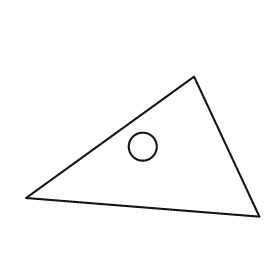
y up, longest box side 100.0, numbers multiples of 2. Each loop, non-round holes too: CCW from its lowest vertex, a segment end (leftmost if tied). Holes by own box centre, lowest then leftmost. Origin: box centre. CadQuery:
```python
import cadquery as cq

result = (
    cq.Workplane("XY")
    .moveTo(50.0, -30.0)
    .lineTo(22.0, 30.0)
    .lineTo(-50.0, -22.0)
    .close()
    .moveTo(0.0, 0.0)
    .circle(6.0)
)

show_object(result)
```